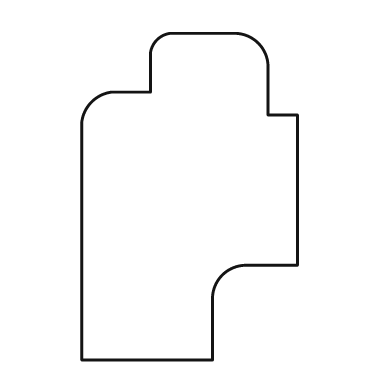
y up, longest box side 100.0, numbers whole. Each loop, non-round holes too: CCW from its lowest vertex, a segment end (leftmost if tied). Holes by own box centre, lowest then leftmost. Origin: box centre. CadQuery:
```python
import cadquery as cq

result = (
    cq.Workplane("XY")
    .moveTo(-33.0, -50.0)
    .lineTo(7.0, -50.0)
    .lineTo(7.0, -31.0)
    .threePointArc((10.0, -24.0), (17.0, -21.0))
    .lineTo(33.0, -21.0)
    .lineTo(33.0, 25.0)
    .lineTo(24.0, 25.0)
    .lineTo(24.0, 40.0)
    .threePointArc((21.0, 47.0), (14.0, 50.0))
    .lineTo(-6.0, 50.0)
    .threePointArc((-10.0, 48.0), (-12.0, 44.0))
    .lineTo(-12.0, 32.0)
    .lineTo(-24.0, 32.0)
    .threePointArc((-30.0, 29.0), (-33.0, 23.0))
    .close()
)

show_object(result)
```